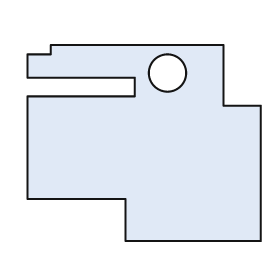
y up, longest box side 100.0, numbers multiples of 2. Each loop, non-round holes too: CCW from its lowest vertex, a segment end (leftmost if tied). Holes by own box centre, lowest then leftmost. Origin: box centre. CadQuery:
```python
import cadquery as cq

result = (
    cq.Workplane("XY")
    .moveTo(-8.0, -42.0)
    .lineTo(50.0, -42.0)
    .lineTo(50.0, 16.0)
    .lineTo(34.0, 16.0)
    .lineTo(34.0, 42.0)
    .lineTo(-40.0, 42.0)
    .lineTo(-40.0, 38.0)
    .lineTo(-50.0, 38.0)
    .lineTo(-50.0, 28.0)
    .lineTo(-4.0, 28.0)
    .lineTo(-4.0, 20.0)
    .lineTo(-50.0, 20.0)
    .lineTo(-50.0, -24.0)
    .lineTo(-8.0, -24.0)
    .close()
    .moveTo(10.0, 30.0)
    .circle(8.0)
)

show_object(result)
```